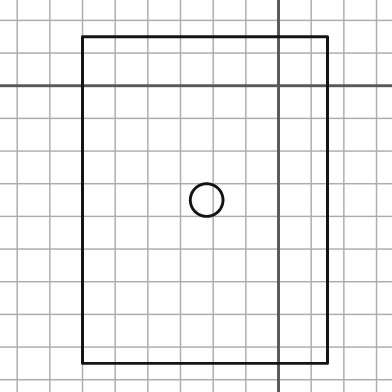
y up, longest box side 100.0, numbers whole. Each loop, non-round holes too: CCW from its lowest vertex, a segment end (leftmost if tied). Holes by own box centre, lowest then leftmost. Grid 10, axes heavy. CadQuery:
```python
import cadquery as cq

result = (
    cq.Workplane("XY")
    .moveTo(-60.0, -85.0)
    .lineTo(15.0, -85.0)
    .lineTo(15.0, 15.0)
    .lineTo(-60.0, 15.0)
    .close()
    .moveTo(-22.0, -35.0)
    .circle(5.0)
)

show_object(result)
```